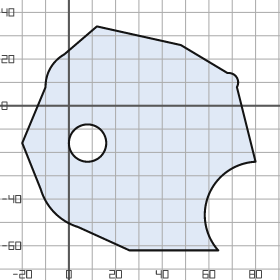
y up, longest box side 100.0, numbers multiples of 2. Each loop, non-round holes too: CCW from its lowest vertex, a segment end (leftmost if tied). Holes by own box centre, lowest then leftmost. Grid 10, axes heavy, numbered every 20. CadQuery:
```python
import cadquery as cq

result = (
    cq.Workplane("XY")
    .moveTo(26.0, -62.0)
    .lineTo(64.0, -62.0)
    .threePointArc((60.0, -38.0), (80.0, -24.0))
    .lineTo(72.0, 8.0)
    .threePointArc((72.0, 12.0), (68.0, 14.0))
    .lineTo(48.0, 26.0)
    .lineTo(12.0, 34.0)
    .lineTo(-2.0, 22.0)
    .threePointArc((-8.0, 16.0), (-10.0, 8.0))
    .lineTo(-20.0, -16.0)
    .lineTo(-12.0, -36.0)
    .threePointArc((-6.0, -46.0), (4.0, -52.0))
    .close()
    .moveTo(8.0, -16.0)
    .circle(8.0)
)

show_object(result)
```